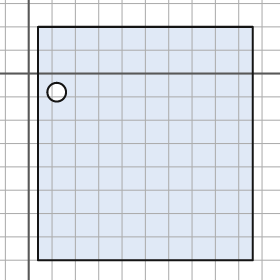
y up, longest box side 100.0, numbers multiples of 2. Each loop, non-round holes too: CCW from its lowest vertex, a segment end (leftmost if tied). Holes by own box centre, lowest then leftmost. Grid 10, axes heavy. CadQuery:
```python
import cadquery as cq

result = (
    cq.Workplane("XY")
    .moveTo(4.0, -80.0)
    .lineTo(96.0, -80.0)
    .lineTo(96.0, 20.0)
    .lineTo(4.0, 20.0)
    .close()
    .moveTo(12.0, -8.0)
    .circle(4.0)
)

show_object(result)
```